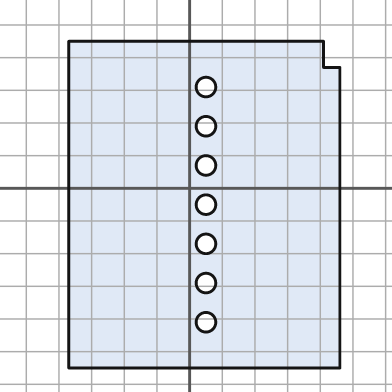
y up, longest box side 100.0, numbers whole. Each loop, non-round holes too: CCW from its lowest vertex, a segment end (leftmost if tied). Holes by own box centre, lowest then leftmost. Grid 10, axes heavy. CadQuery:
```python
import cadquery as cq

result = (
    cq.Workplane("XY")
    .moveTo(-37.0, -55.0)
    .lineTo(46.0, -55.0)
    .lineTo(46.0, 37.0)
    .lineTo(41.0, 37.0)
    .lineTo(41.0, 45.0)
    .lineTo(-37.0, 45.0)
    .close()
    .moveTo(5.0, -41.0)
    .circle(3.0)
    .moveTo(5.0, -29.0)
    .circle(3.0)
    .moveTo(5.0, -17.0)
    .circle(3.0)
    .moveTo(5.0, -5.0)
    .circle(3.0)
    .moveTo(5.0, 7.0)
    .circle(3.0)
    .moveTo(5.0, 19.0)
    .circle(3.0)
    .moveTo(5.0, 31.0)
    .circle(3.0)
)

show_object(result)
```